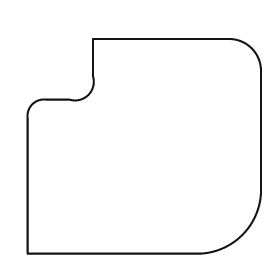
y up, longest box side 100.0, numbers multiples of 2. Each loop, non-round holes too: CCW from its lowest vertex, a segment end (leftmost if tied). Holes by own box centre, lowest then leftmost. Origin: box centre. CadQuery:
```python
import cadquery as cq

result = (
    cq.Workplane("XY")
    .moveTo(-50.0, -46.0)
    .lineTo(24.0, -46.0)
    .threePointArc((42.0, -38.0), (50.0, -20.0))
    .lineTo(50.0, 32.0)
    .threePointArc((46.0, 42.0), (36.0, 46.0))
    .lineTo(-22.0, 46.0)
    .lineTo(-22.0, 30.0)
    .threePointArc((-24.0, 22.0), (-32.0, 20.0))
    .lineTo(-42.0, 20.0)
    .threePointArc((-48.0, 18.0), (-50.0, 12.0))
    .close()
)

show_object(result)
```